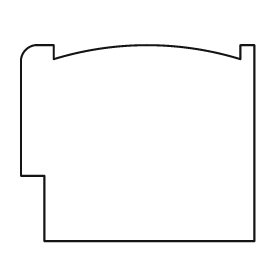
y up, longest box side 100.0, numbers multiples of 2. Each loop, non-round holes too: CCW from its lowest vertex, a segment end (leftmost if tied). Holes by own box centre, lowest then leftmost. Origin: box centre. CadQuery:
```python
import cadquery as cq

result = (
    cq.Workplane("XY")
    .moveTo(-40.0, -42.0)
    .lineTo(50.0, -42.0)
    .lineTo(50.0, 42.0)
    .lineTo(44.0, 42.0)
    .lineTo(44.0, 36.0)
    .threePointArc((4.0, 42.0), (-36.0, 36.0))
    .lineTo(-36.0, 42.0)
    .lineTo(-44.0, 42.0)
    .threePointArc((-48.0, 40.0), (-50.0, 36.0))
    .lineTo(-50.0, -14.0)
    .lineTo(-40.0, -14.0)
    .close()
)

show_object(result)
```